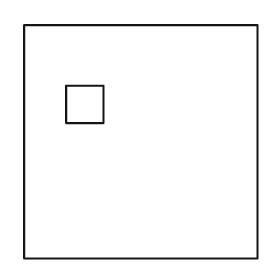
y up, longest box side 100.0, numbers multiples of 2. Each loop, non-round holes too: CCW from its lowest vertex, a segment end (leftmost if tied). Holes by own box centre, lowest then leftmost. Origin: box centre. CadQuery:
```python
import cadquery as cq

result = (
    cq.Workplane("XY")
    .moveTo(-50.0, -50.0)
    .lineTo(50.0, -50.0)
    .lineTo(50.0, 50.0)
    .lineTo(-50.0, 50.0)
    .close()
    .moveTo(-32.0, 8.0)
    .lineTo(-16.0, 8.0)
    .lineTo(-16.0, 24.0)
    .lineTo(-32.0, 24.0)
    .close()
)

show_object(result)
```